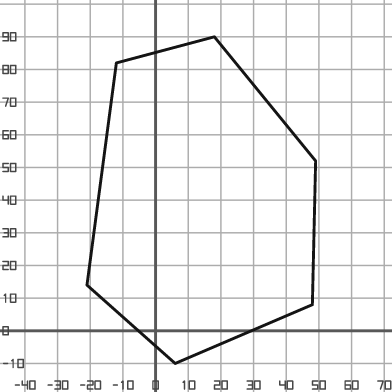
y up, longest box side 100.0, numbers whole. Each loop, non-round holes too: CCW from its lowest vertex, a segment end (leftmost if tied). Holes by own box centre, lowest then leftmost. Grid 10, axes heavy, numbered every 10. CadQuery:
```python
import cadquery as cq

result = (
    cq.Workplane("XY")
    .moveTo(6.0, -10.0)
    .lineTo(48.0, 8.0)
    .lineTo(49.0, 52.0)
    .lineTo(18.0, 90.0)
    .lineTo(-12.0, 82.0)
    .lineTo(-21.0, 14.0)
    .close()
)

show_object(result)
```